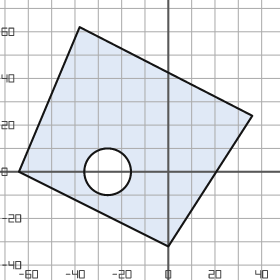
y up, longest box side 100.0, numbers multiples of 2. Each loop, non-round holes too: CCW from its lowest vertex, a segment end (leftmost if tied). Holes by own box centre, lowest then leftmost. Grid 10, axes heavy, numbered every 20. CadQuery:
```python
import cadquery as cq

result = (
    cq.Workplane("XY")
    .moveTo(0.0, -32.0)
    .lineTo(36.0, 24.0)
    .lineTo(-38.0, 62.0)
    .lineTo(-64.0, 0.0)
    .close()
    .moveTo(-26.0, 0.0)
    .circle(10.0)
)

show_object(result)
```